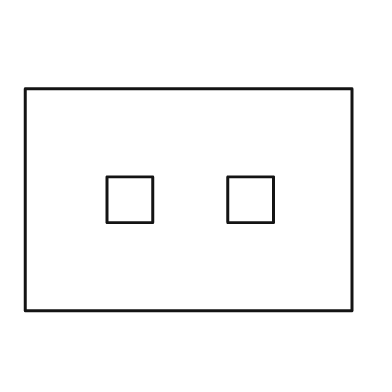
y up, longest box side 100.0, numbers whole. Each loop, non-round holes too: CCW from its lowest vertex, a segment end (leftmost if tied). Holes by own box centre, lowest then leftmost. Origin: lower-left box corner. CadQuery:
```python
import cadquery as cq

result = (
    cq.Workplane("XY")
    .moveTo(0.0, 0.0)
    .lineTo(100.0, 0.0)
    .lineTo(100.0, 68.0)
    .lineTo(0.0, 68.0)
    .close()
    .moveTo(25.0, 27.0)
    .lineTo(39.0, 27.0)
    .lineTo(39.0, 41.0)
    .lineTo(25.0, 41.0)
    .close()
    .moveTo(62.0, 27.0)
    .lineTo(76.0, 27.0)
    .lineTo(76.0, 41.0)
    .lineTo(62.0, 41.0)
    .close()
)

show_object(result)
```